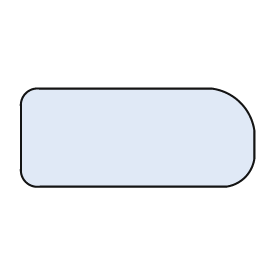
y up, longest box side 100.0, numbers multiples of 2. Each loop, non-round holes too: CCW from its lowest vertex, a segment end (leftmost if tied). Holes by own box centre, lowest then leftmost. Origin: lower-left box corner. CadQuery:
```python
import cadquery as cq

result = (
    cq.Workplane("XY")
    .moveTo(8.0, 0.0)
    .lineTo(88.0, 0.0)
    .threePointArc((96.0, 4.0), (100.0, 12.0))
    .lineTo(100.0, 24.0)
    .threePointArc((94.0, 36.0), (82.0, 42.0))
    .lineTo(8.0, 42.0)
    .threePointArc((2.0, 40.0), (0.0, 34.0))
    .lineTo(0.0, 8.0)
    .threePointArc((2.0, 2.0), (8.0, 0.0))
    .close()
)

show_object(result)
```